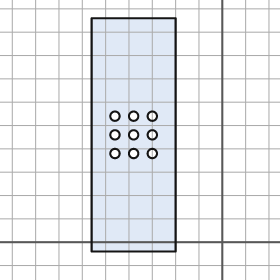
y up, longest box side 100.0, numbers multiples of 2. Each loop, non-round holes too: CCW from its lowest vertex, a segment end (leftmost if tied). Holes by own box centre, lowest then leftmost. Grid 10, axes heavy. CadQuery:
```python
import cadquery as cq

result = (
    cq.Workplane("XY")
    .moveTo(-56.0, -4.0)
    .lineTo(-20.0, -4.0)
    .lineTo(-20.0, 96.0)
    .lineTo(-56.0, 96.0)
    .close()
    .moveTo(-46.0, 38.0)
    .circle(2.0)
    .moveTo(-38.0, 38.0)
    .circle(2.0)
    .moveTo(-30.0, 38.0)
    .circle(2.0)
    .moveTo(-46.0, 46.0)
    .circle(2.0)
    .moveTo(-38.0, 46.0)
    .circle(2.0)
    .moveTo(-30.0, 46.0)
    .circle(2.0)
    .moveTo(-46.0, 54.0)
    .circle(2.0)
    .moveTo(-38.0, 54.0)
    .circle(2.0)
    .moveTo(-30.0, 54.0)
    .circle(2.0)
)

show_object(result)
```